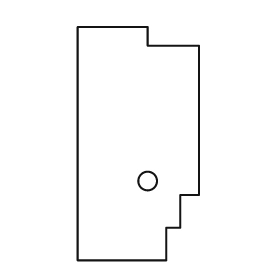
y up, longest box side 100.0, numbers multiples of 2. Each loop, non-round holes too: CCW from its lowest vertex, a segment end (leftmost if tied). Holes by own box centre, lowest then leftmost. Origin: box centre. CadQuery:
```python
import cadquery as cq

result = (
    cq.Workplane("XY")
    .moveTo(-26.0, -50.0)
    .lineTo(12.0, -50.0)
    .lineTo(12.0, -36.0)
    .lineTo(18.0, -36.0)
    .lineTo(18.0, -22.0)
    .lineTo(26.0, -22.0)
    .lineTo(26.0, 42.0)
    .lineTo(4.0, 42.0)
    .lineTo(4.0, 50.0)
    .lineTo(-26.0, 50.0)
    .close()
    .moveTo(4.0, -16.0)
    .circle(4.0)
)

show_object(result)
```